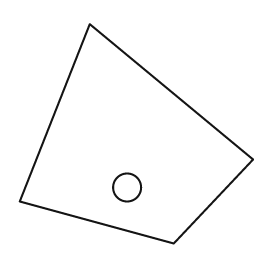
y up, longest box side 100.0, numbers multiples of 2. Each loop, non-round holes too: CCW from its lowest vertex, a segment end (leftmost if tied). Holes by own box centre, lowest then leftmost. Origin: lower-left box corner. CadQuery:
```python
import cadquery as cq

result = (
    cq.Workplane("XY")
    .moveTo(66.0, 0.0)
    .lineTo(100.0, 36.0)
    .lineTo(30.0, 94.0)
    .lineTo(0.0, 18.0)
    .close()
    .moveTo(46.0, 24.0)
    .circle(6.0)
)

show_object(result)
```